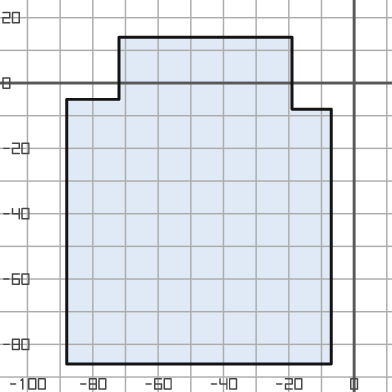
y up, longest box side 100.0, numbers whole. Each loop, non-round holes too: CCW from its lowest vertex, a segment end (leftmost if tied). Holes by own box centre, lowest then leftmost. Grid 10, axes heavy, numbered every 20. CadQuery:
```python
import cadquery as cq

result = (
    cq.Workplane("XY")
    .moveTo(-88.0, -86.0)
    .lineTo(-7.0, -86.0)
    .lineTo(-7.0, -8.0)
    .lineTo(-19.0, -8.0)
    .lineTo(-19.0, 14.0)
    .lineTo(-72.0, 14.0)
    .lineTo(-72.0, -5.0)
    .lineTo(-88.0, -5.0)
    .close()
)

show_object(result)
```